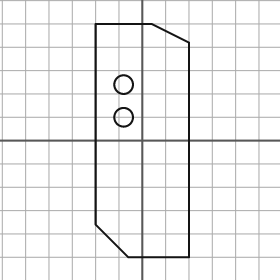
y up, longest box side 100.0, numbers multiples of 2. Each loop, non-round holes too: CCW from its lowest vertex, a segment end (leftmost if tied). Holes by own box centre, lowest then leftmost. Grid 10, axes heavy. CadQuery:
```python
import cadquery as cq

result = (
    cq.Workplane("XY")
    .moveTo(-6.0, -50.0)
    .lineTo(20.0, -50.0)
    .lineTo(20.0, 42.0)
    .lineTo(4.0, 50.0)
    .lineTo(-20.0, 50.0)
    .lineTo(-20.0, -36.0)
    .close()
    .moveTo(-8.0, 10.0)
    .circle(4.0)
    .moveTo(-8.0, 24.0)
    .circle(4.0)
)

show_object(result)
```